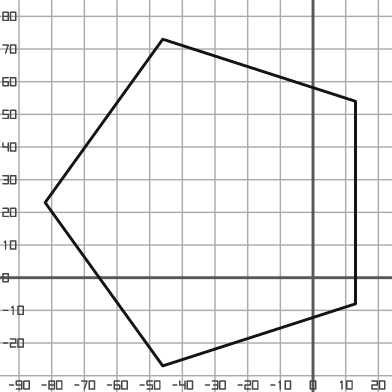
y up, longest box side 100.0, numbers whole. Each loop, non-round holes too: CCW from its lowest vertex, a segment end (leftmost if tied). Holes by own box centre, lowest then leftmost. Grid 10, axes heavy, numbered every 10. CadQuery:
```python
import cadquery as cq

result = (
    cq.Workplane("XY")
    .moveTo(-46.0, -27.0)
    .lineTo(13.0, -8.0)
    .lineTo(13.0, 54.0)
    .lineTo(-46.0, 73.0)
    .lineTo(-82.0, 23.0)
    .close()
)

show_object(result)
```